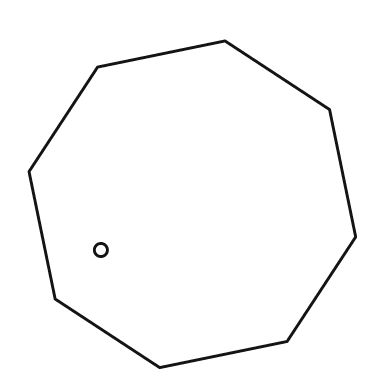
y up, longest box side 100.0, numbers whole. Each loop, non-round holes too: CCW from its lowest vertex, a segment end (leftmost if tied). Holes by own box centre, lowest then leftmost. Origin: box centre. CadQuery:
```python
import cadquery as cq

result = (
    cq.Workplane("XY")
    .moveTo(-10.0, -50.0)
    .lineTo(29.0, -42.0)
    .lineTo(50.0, -10.0)
    .lineTo(42.0, 29.0)
    .lineTo(10.0, 50.0)
    .lineTo(-29.0, 42.0)
    .lineTo(-50.0, 10.0)
    .lineTo(-42.0, -29.0)
    .close()
    .moveTo(-28.0, -14.0)
    .circle(2.0)
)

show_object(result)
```